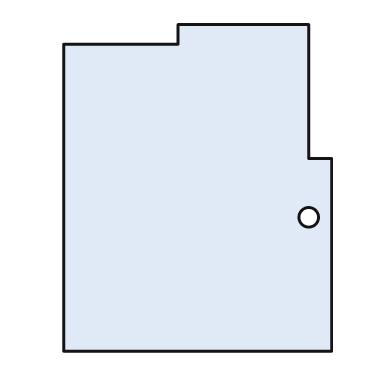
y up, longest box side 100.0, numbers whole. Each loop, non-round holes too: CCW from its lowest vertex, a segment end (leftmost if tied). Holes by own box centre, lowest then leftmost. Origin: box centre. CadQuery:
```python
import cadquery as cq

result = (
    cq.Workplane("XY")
    .moveTo(-41.0, -50.0)
    .lineTo(41.0, -50.0)
    .lineTo(41.0, 9.0)
    .lineTo(34.0, 9.0)
    .lineTo(34.0, 50.0)
    .lineTo(-6.0, 50.0)
    .lineTo(-6.0, 44.0)
    .lineTo(-41.0, 44.0)
    .close()
    .moveTo(34.0, -9.0)
    .circle(3.0)
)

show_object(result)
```